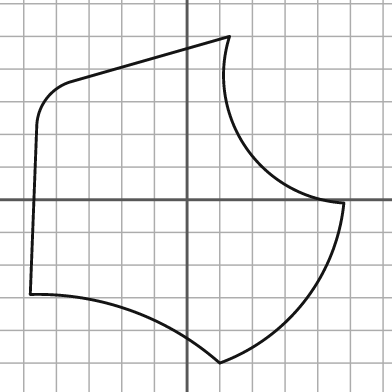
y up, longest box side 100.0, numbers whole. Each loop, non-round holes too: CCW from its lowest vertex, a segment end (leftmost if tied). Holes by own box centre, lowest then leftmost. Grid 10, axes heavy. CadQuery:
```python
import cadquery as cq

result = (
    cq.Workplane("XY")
    .moveTo(10.0, -50.0)
    .threePointArc((36.0, -31.0), (48.0, -1.0))
    .threePointArc((18.0, 16.0), (13.0, 50.0))
    .lineTo(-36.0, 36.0)
    .threePointArc((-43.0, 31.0), (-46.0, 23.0))
    .lineTo(-48.0, -29.0)
    .threePointArc((-17.0, -34.0), (10.0, -50.0))
    .close()
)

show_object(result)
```